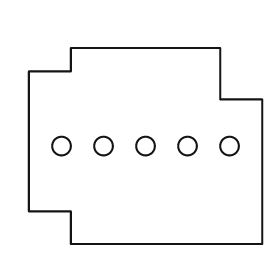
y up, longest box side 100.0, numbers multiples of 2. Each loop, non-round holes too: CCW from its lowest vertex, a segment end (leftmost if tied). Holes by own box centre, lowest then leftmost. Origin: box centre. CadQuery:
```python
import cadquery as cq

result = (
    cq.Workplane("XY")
    .moveTo(-32.0, -42.0)
    .lineTo(50.0, -42.0)
    .lineTo(50.0, 20.0)
    .lineTo(32.0, 20.0)
    .lineTo(32.0, 42.0)
    .lineTo(-32.0, 42.0)
    .lineTo(-32.0, 32.0)
    .lineTo(-50.0, 32.0)
    .lineTo(-50.0, -28.0)
    .lineTo(-32.0, -28.0)
    .close()
    .moveTo(-36.0, 0.0)
    .circle(4.0)
    .moveTo(-18.0, 0.0)
    .circle(4.0)
    .moveTo(0.0, 0.0)
    .circle(4.0)
    .moveTo(18.0, 0.0)
    .circle(4.0)
    .moveTo(36.0, 0.0)
    .circle(4.0)
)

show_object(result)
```